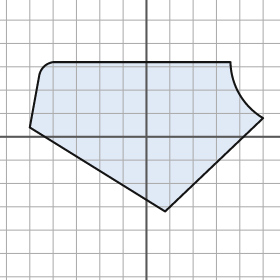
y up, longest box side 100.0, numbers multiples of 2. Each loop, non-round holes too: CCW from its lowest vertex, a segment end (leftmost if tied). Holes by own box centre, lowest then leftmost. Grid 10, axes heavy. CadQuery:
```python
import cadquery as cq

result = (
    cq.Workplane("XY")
    .moveTo(8.0, -32.0)
    .lineTo(50.0, 8.0)
    .threePointArc((40.0, 18.0), (36.0, 32.0))
    .lineTo(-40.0, 32.0)
    .threePointArc((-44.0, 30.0), (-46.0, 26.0))
    .lineTo(-50.0, 4.0)
    .close()
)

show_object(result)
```